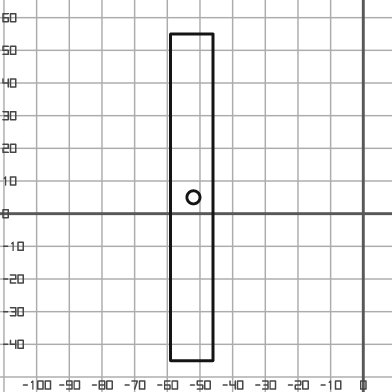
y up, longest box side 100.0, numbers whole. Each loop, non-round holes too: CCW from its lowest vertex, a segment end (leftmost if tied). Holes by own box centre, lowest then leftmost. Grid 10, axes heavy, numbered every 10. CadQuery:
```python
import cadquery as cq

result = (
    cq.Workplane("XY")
    .moveTo(-59.0, -45.0)
    .lineTo(-46.0, -45.0)
    .lineTo(-46.0, 55.0)
    .lineTo(-59.0, 55.0)
    .close()
    .moveTo(-52.0, 5.0)
    .circle(2.0)
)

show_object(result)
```